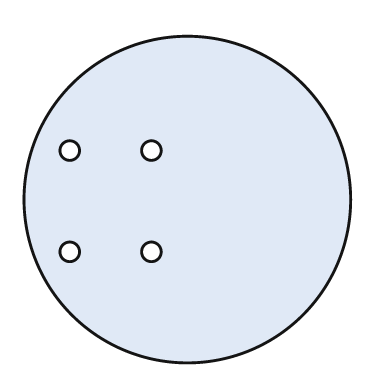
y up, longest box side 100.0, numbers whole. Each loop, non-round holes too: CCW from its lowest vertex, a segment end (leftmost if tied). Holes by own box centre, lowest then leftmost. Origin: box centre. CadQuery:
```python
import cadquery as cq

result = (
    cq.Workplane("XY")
    .moveTo(0.0, 0.0)
    .circle(50.0)
    .moveTo(-36.0, -16.0)
    .circle(3.0)
    .moveTo(-11.0, -16.0)
    .circle(3.0)
    .moveTo(-36.0, 15.0)
    .circle(3.0)
    .moveTo(-11.0, 15.0)
    .circle(3.0)
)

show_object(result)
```